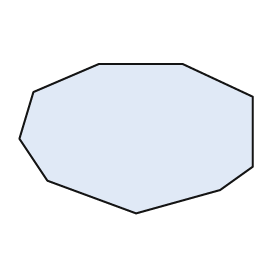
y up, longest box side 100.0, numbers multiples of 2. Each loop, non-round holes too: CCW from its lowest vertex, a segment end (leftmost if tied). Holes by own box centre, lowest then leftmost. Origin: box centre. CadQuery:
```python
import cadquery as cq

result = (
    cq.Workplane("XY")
    .moveTo(0.0, -32.0)
    .lineTo(36.0, -22.0)
    .lineTo(50.0, -12.0)
    .lineTo(50.0, 18.0)
    .lineTo(20.0, 32.0)
    .lineTo(-16.0, 32.0)
    .lineTo(-44.0, 20.0)
    .lineTo(-50.0, 0.0)
    .lineTo(-38.0, -18.0)
    .close()
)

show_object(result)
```